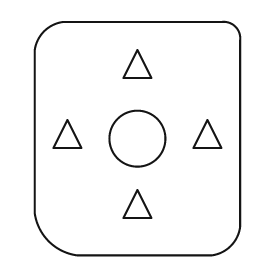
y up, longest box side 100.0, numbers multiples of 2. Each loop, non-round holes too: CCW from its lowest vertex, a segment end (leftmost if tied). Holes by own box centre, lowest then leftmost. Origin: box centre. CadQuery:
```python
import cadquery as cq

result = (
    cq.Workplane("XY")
    .moveTo(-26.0, -50.0)
    .lineTo(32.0, -50.0)
    .threePointArc((40.0, -46.0), (44.0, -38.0))
    .lineTo(44.0, 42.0)
    .threePointArc((42.0, 48.0), (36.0, 50.0))
    .lineTo(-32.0, 50.0)
    .threePointArc((-40.0, 46.0), (-44.0, 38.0))
    .lineTo(-44.0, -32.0)
    .threePointArc((-38.0, -44.0), (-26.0, -50.0))
    .close()
    .moveTo(-6.0, -34.0)
    .lineTo(6.0, -34.0)
    .lineTo(0.0, -22.0)
    .close()
    .moveTo(0.0, 0.0)
    .circle(12.0)
    .moveTo(-36.0, -4.0)
    .lineTo(-24.0, -4.0)
    .lineTo(-30.0, 8.0)
    .close()
    .moveTo(24.0, -4.0)
    .lineTo(36.0, -4.0)
    .lineTo(30.0, 8.0)
    .close()
    .moveTo(-6.0, 26.0)
    .lineTo(6.0, 26.0)
    .lineTo(0.0, 38.0)
    .close()
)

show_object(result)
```